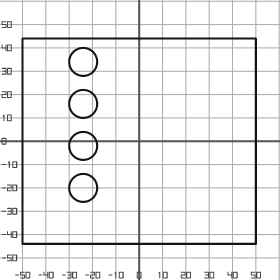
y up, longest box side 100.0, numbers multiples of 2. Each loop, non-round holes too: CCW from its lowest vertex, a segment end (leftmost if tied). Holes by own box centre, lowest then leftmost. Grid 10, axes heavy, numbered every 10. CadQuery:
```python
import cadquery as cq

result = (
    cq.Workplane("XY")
    .moveTo(-50.0, -44.0)
    .lineTo(50.0, -44.0)
    .lineTo(50.0, 44.0)
    .lineTo(-50.0, 44.0)
    .close()
    .moveTo(-24.0, -20.0)
    .circle(6.0)
    .moveTo(-24.0, -2.0)
    .circle(6.0)
    .moveTo(-24.0, 16.0)
    .circle(6.0)
    .moveTo(-24.0, 34.0)
    .circle(6.0)
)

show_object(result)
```